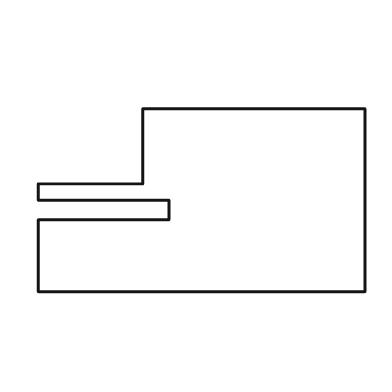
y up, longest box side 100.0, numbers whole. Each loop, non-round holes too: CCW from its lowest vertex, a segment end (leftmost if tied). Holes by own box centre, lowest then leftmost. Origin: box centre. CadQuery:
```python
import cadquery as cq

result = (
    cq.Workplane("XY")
    .moveTo(-50.0, -28.0)
    .lineTo(50.0, -28.0)
    .lineTo(50.0, 28.0)
    .lineTo(-18.0, 28.0)
    .lineTo(-18.0, 5.0)
    .lineTo(-50.0, 5.0)
    .lineTo(-50.0, 0.0)
    .lineTo(-10.0, 0.0)
    .lineTo(-10.0, -6.0)
    .lineTo(-50.0, -6.0)
    .close()
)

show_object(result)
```